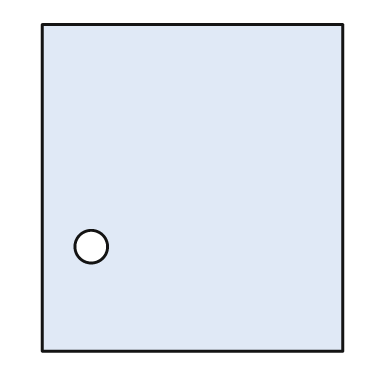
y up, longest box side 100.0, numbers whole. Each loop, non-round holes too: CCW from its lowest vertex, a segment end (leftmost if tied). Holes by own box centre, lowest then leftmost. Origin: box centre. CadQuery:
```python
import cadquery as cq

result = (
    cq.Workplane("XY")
    .moveTo(-46.0, -50.0)
    .lineTo(46.0, -50.0)
    .lineTo(46.0, 50.0)
    .lineTo(-46.0, 50.0)
    .close()
    .moveTo(-31.0, -18.0)
    .circle(5.0)
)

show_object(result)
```